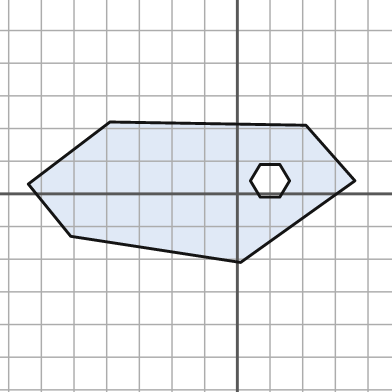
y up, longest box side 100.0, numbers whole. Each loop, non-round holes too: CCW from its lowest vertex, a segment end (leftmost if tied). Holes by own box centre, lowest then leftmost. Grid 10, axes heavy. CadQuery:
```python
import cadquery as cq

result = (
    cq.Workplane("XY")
    .moveTo(1.0, -21.0)
    .lineTo(36.0, 4.0)
    .lineTo(21.0, 21.0)
    .lineTo(-39.0, 22.0)
    .lineTo(-64.0, 3.0)
    .lineTo(-51.0, -13.0)
    .close()
    .moveTo(7.0, -1.0)
    .lineTo(13.0, -1.0)
    .lineTo(16.0, 4.0)
    .lineTo(13.0, 9.0)
    .lineTo(7.0, 9.0)
    .lineTo(4.0, 4.0)
    .close()
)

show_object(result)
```